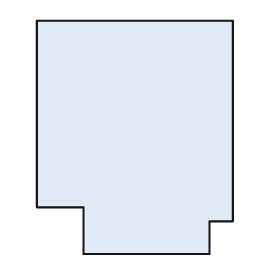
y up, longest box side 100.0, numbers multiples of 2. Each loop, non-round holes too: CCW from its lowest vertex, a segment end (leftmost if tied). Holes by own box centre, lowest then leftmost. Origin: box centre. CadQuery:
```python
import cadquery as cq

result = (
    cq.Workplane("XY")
    .moveTo(-22.0, -50.0)
    .lineTo(32.0, -50.0)
    .lineTo(32.0, -36.0)
    .lineTo(42.0, -36.0)
    .lineTo(42.0, 50.0)
    .lineTo(-42.0, 50.0)
    .lineTo(-42.0, -30.0)
    .lineTo(-22.0, -30.0)
    .close()
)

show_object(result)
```